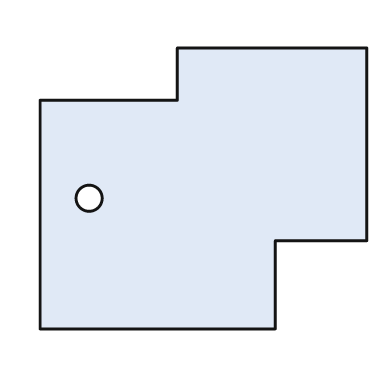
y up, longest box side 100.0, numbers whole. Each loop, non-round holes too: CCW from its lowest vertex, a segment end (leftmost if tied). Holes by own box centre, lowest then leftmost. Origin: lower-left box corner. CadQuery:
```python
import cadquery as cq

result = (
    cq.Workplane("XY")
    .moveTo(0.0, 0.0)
    .lineTo(72.0, 0.0)
    .lineTo(72.0, 27.0)
    .lineTo(100.0, 27.0)
    .lineTo(100.0, 86.0)
    .lineTo(42.0, 86.0)
    .lineTo(42.0, 70.0)
    .lineTo(0.0, 70.0)
    .close()
    .moveTo(15.0, 40.0)
    .circle(4.0)
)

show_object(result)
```